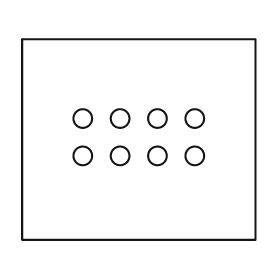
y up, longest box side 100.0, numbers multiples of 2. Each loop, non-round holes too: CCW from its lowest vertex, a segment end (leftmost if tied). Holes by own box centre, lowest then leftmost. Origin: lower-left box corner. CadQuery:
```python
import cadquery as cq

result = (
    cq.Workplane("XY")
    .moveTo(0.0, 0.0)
    .lineTo(100.0, 0.0)
    .lineTo(100.0, 86.0)
    .lineTo(0.0, 86.0)
    .close()
    .moveTo(26.0, 36.0)
    .circle(4.0)
    .moveTo(42.0, 36.0)
    .circle(4.0)
    .moveTo(58.0, 36.0)
    .circle(4.0)
    .moveTo(74.0, 36.0)
    .circle(4.0)
    .moveTo(26.0, 52.0)
    .circle(4.0)
    .moveTo(42.0, 52.0)
    .circle(4.0)
    .moveTo(58.0, 52.0)
    .circle(4.0)
    .moveTo(74.0, 52.0)
    .circle(4.0)
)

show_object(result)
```